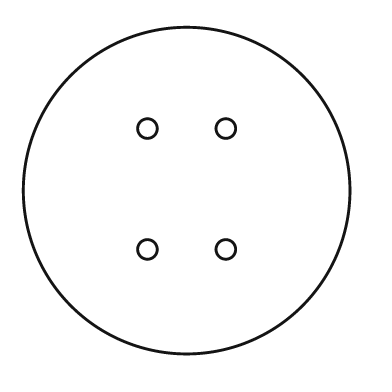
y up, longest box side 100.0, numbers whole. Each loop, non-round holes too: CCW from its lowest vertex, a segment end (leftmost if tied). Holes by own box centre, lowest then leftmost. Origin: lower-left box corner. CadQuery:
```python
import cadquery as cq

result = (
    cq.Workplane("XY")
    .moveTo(50.0, 50.0)
    .circle(50.0)
    .moveTo(38.0, 32.0)
    .circle(3.0)
    .moveTo(62.0, 32.0)
    .circle(3.0)
    .moveTo(38.0, 69.0)
    .circle(3.0)
    .moveTo(62.0, 69.0)
    .circle(3.0)
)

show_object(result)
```